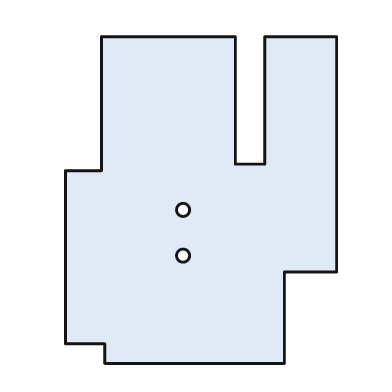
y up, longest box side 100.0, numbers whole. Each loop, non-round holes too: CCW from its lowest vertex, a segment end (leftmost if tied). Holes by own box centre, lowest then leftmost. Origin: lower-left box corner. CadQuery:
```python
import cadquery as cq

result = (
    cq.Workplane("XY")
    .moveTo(12.0, 0.0)
    .lineTo(67.0, 0.0)
    .lineTo(67.0, 28.0)
    .lineTo(83.0, 28.0)
    .lineTo(83.0, 100.0)
    .lineTo(61.0, 100.0)
    .lineTo(61.0, 61.0)
    .lineTo(52.0, 61.0)
    .lineTo(52.0, 100.0)
    .lineTo(11.0, 100.0)
    .lineTo(11.0, 59.0)
    .lineTo(0.0, 59.0)
    .lineTo(0.0, 6.0)
    .lineTo(12.0, 6.0)
    .close()
    .moveTo(36.0, 33.0)
    .circle(2.0)
    .moveTo(36.0, 47.0)
    .circle(2.0)
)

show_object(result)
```